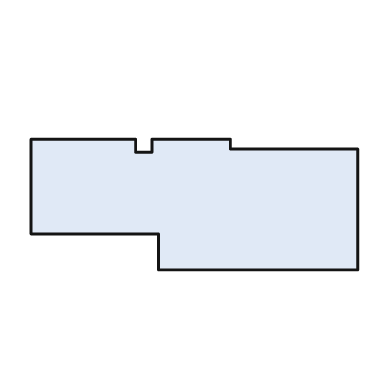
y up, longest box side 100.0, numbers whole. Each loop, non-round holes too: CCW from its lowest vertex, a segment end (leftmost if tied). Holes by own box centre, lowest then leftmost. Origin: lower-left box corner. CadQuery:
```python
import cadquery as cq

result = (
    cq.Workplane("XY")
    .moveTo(39.0, 0.0)
    .lineTo(100.0, 0.0)
    .lineTo(100.0, 37.0)
    .lineTo(61.0, 37.0)
    .lineTo(61.0, 40.0)
    .lineTo(37.0, 40.0)
    .lineTo(37.0, 36.0)
    .lineTo(32.0, 36.0)
    .lineTo(32.0, 40.0)
    .lineTo(0.0, 40.0)
    .lineTo(0.0, 11.0)
    .lineTo(39.0, 11.0)
    .close()
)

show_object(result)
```